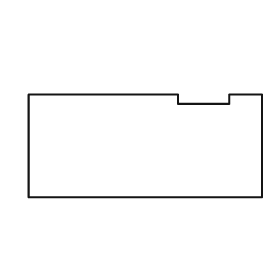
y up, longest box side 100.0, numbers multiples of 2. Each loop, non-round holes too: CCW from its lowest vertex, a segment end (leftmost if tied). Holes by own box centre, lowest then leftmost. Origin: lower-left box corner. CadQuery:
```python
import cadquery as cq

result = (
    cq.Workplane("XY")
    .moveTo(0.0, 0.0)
    .lineTo(100.0, 0.0)
    .lineTo(100.0, 44.0)
    .lineTo(86.0, 44.0)
    .lineTo(86.0, 40.0)
    .lineTo(64.0, 40.0)
    .lineTo(64.0, 44.0)
    .lineTo(0.0, 44.0)
    .close()
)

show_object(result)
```